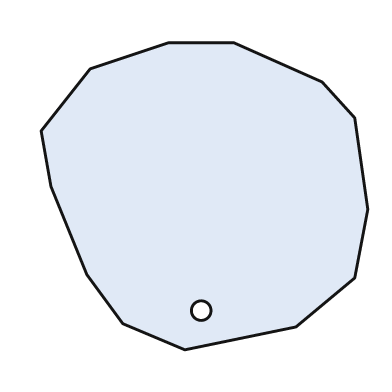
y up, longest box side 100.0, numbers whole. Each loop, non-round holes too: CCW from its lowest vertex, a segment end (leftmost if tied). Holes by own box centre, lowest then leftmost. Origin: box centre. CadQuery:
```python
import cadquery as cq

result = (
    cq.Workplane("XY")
    .moveTo(-6.0, -47.0)
    .lineTo(28.0, -40.0)
    .lineTo(46.0, -25.0)
    .lineTo(50.0, -4.0)
    .lineTo(46.0, 24.0)
    .lineTo(36.0, 35.0)
    .lineTo(9.0, 47.0)
    .lineTo(-11.0, 47.0)
    .lineTo(-35.0, 39.0)
    .lineTo(-50.0, 20.0)
    .lineTo(-47.0, 3.0)
    .lineTo(-36.0, -24.0)
    .lineTo(-25.0, -39.0)
    .close()
    .moveTo(-1.0, -35.0)
    .circle(3.0)
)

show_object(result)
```